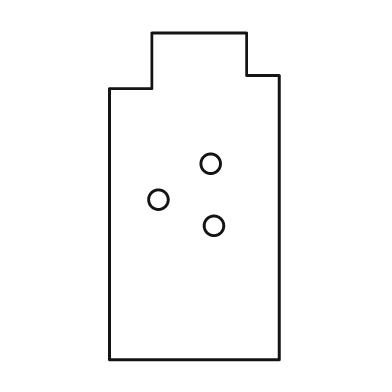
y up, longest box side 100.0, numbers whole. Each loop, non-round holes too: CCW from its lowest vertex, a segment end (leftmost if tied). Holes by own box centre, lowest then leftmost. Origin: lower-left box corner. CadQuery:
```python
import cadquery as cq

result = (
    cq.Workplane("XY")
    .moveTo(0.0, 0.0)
    .lineTo(52.0, 0.0)
    .lineTo(52.0, 87.0)
    .lineTo(42.0, 87.0)
    .lineTo(42.0, 100.0)
    .lineTo(13.0, 100.0)
    .lineTo(13.0, 83.0)
    .lineTo(0.0, 83.0)
    .close()
    .moveTo(32.0, 41.0)
    .circle(3.0)
    .moveTo(15.0, 49.0)
    .circle(3.0)
    .moveTo(31.0, 60.0)
    .circle(3.0)
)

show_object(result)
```